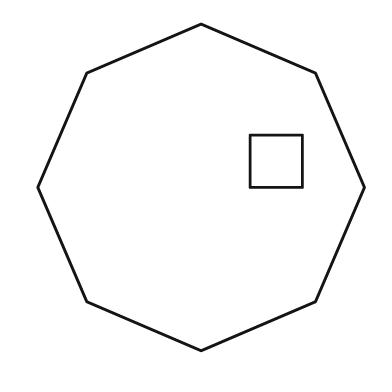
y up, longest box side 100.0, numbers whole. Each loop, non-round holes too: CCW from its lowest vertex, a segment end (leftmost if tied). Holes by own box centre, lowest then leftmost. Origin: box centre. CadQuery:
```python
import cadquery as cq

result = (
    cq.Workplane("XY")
    .moveTo(0.0, -50.0)
    .lineTo(35.0, -35.0)
    .lineTo(50.0, 0.0)
    .lineTo(35.0, 35.0)
    .lineTo(0.0, 50.0)
    .lineTo(-35.0, 35.0)
    .lineTo(-50.0, 0.0)
    .lineTo(-35.0, -35.0)
    .close()
    .moveTo(15.0, 0.0)
    .lineTo(31.0, 0.0)
    .lineTo(31.0, 16.0)
    .lineTo(15.0, 16.0)
    .close()
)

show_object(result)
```